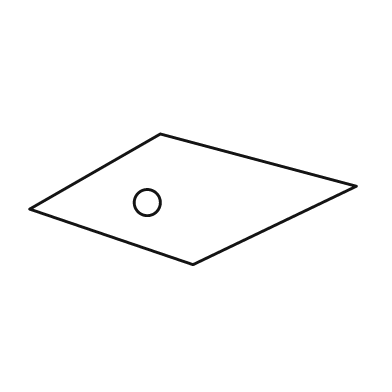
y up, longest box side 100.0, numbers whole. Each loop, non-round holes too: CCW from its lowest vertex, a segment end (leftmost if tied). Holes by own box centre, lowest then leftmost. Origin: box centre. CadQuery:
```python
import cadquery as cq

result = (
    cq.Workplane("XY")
    .moveTo(0.0, -20.0)
    .lineTo(50.0, 4.0)
    .lineTo(-10.0, 20.0)
    .lineTo(-50.0, -3.0)
    .close()
    .moveTo(-14.0, -1.0)
    .circle(4.0)
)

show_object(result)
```